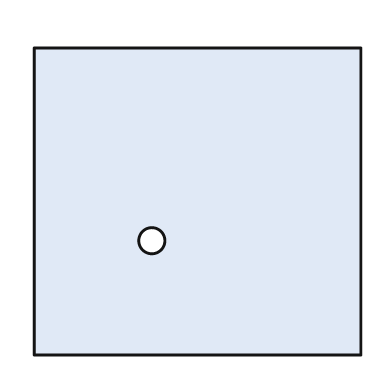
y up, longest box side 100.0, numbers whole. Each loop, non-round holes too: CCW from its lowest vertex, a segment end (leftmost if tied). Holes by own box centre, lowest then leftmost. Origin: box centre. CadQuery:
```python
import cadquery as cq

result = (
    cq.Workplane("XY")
    .moveTo(-50.0, -47.0)
    .lineTo(50.0, -47.0)
    .lineTo(50.0, 47.0)
    .lineTo(-50.0, 47.0)
    .close()
    .moveTo(-14.0, -12.0)
    .circle(4.0)
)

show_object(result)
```